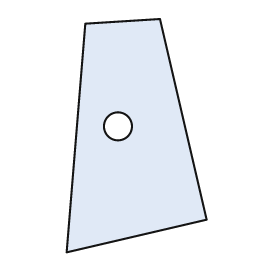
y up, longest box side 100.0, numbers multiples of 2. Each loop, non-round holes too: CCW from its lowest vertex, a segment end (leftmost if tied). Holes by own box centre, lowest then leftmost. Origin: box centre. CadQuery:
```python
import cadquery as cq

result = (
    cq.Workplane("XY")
    .moveTo(-30.0, -50.0)
    .lineTo(30.0, -36.0)
    .lineTo(10.0, 50.0)
    .lineTo(-22.0, 48.0)
    .close()
    .moveTo(-8.0, 4.0)
    .circle(6.0)
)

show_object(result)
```